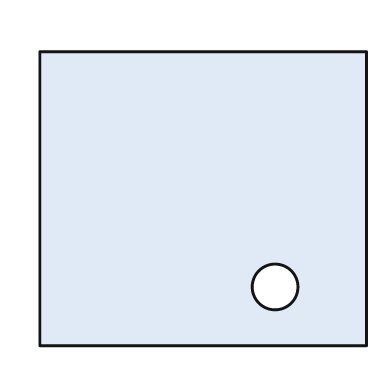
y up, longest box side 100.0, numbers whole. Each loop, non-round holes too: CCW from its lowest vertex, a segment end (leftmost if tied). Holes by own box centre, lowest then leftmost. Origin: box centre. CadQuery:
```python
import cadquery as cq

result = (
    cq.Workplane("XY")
    .moveTo(-50.0, -45.0)
    .lineTo(50.0, -45.0)
    .lineTo(50.0, 45.0)
    .lineTo(-50.0, 45.0)
    .close()
    .moveTo(22.0, -27.0)
    .circle(7.0)
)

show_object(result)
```